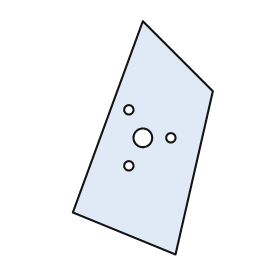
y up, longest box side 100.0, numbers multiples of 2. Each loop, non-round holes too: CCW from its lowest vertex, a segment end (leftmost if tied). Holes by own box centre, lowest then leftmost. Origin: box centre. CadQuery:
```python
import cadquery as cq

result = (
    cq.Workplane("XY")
    .moveTo(14.0, -50.0)
    .lineTo(30.0, 20.0)
    .lineTo(0.0, 50.0)
    .lineTo(-30.0, -32.0)
    .close()
    .moveTo(-6.0, -12.0)
    .circle(2.0)
    .moveTo(0.0, 0.0)
    .circle(4.0)
    .moveTo(12.0, 0.0)
    .circle(2.0)
    .moveTo(-6.0, 12.0)
    .circle(2.0)
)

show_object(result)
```